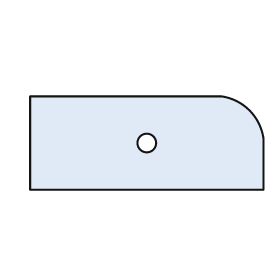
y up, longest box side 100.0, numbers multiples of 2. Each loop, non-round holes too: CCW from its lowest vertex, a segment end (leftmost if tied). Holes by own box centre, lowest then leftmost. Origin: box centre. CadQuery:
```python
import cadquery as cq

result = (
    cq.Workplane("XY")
    .moveTo(-50.0, -20.0)
    .lineTo(50.0, -20.0)
    .lineTo(50.0, 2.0)
    .threePointArc((44.0, 14.0), (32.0, 20.0))
    .lineTo(-50.0, 20.0)
    .close()
    .moveTo(0.0, 0.0)
    .circle(4.0)
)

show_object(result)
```